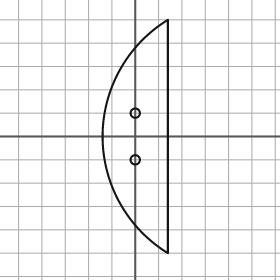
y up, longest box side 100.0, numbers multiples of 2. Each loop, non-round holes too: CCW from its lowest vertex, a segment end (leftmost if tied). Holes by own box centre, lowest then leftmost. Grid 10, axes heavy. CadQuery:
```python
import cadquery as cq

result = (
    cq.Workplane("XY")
    .moveTo(14.0, -50.0)
    .lineTo(14.0, 50.0)
    .threePointArc((-14.0, 0.0), (14.0, -50.0))
    .close()
    .moveTo(0.0, -10.0)
    .circle(2.0)
    .moveTo(0.0, 10.0)
    .circle(2.0)
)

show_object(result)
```